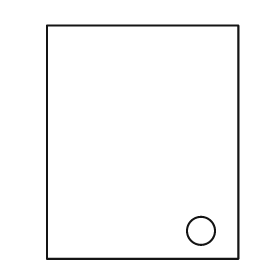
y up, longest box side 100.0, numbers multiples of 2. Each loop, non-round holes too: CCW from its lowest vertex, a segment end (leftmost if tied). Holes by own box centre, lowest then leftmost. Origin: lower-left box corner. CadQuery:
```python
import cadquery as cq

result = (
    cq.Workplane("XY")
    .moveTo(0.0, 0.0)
    .lineTo(82.0, 0.0)
    .lineTo(82.0, 100.0)
    .lineTo(0.0, 100.0)
    .close()
    .moveTo(66.0, 12.0)
    .circle(6.0)
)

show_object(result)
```